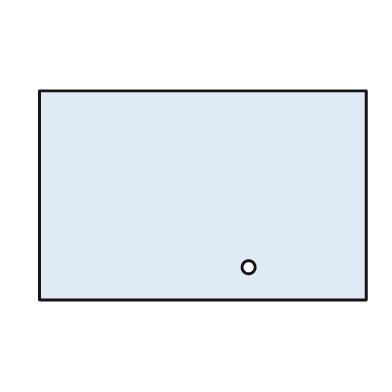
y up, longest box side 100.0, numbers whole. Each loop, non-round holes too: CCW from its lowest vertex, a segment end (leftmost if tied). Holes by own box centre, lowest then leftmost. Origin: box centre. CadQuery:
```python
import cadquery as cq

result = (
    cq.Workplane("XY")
    .moveTo(-50.0, -32.0)
    .lineTo(50.0, -32.0)
    .lineTo(50.0, 32.0)
    .lineTo(-50.0, 32.0)
    .close()
    .moveTo(14.0, -22.0)
    .circle(2.0)
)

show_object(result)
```